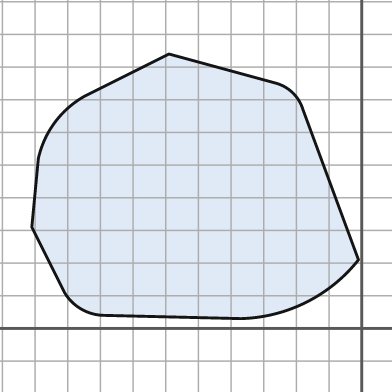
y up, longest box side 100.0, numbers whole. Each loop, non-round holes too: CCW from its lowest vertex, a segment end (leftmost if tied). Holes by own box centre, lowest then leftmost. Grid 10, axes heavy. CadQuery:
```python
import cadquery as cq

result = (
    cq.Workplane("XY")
    .moveTo(-37.0, 3.0)
    .threePointArc((-17.0, 8.0), (-1.0, 21.0))
    .lineTo(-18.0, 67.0)
    .threePointArc((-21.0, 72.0), (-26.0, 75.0))
    .lineTo(-59.0, 84.0)
    .lineTo(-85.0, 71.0)
    .threePointArc((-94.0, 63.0), (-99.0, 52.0))
    .lineTo(-101.0, 31.0)
    .lineTo(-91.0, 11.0)
    .threePointArc((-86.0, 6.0), (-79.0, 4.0))
    .close()
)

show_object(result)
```